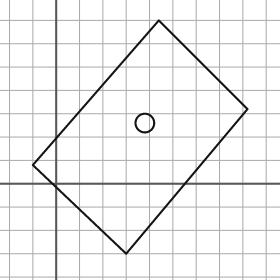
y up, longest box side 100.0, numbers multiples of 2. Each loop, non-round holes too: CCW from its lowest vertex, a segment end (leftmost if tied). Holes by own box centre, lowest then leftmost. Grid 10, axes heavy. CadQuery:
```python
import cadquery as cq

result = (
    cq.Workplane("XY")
    .moveTo(30.0, -30.0)
    .lineTo(82.0, 32.0)
    .lineTo(44.0, 70.0)
    .lineTo(-10.0, 8.0)
    .close()
    .moveTo(38.0, 26.0)
    .circle(4.0)
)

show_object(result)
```